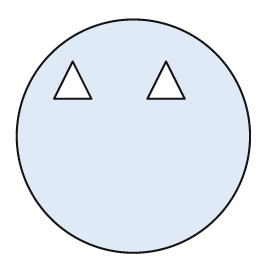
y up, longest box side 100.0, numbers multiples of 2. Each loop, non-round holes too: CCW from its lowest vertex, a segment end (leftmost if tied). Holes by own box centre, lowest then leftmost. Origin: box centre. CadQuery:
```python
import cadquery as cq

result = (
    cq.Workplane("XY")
    .moveTo(0.0, 0.0)
    .circle(50.0)
    .moveTo(-34.0, 16.0)
    .lineTo(-18.0, 16.0)
    .lineTo(-26.0, 32.0)
    .close()
    .moveTo(6.0, 16.0)
    .lineTo(22.0, 16.0)
    .lineTo(14.0, 32.0)
    .close()
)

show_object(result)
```